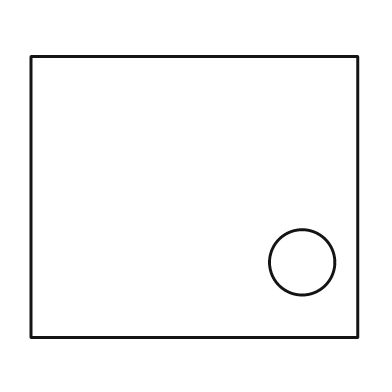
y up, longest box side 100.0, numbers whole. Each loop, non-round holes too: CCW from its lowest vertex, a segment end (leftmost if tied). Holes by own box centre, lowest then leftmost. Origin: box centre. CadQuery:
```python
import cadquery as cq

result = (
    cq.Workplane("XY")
    .moveTo(-50.0, -43.0)
    .lineTo(50.0, -43.0)
    .lineTo(50.0, 43.0)
    .lineTo(-50.0, 43.0)
    .close()
    .moveTo(33.0, -20.0)
    .circle(10.0)
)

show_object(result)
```